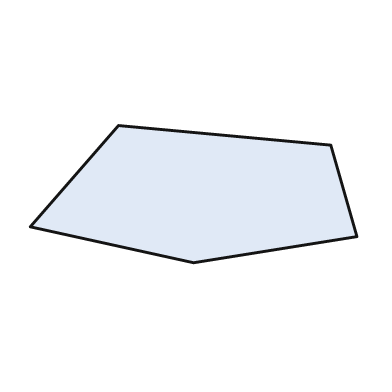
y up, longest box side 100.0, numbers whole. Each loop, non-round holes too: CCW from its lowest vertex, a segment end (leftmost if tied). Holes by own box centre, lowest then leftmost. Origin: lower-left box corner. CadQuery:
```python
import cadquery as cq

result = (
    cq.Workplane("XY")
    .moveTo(50.0, 0.0)
    .lineTo(100.0, 8.0)
    .lineTo(92.0, 36.0)
    .lineTo(27.0, 42.0)
    .lineTo(0.0, 11.0)
    .close()
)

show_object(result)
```